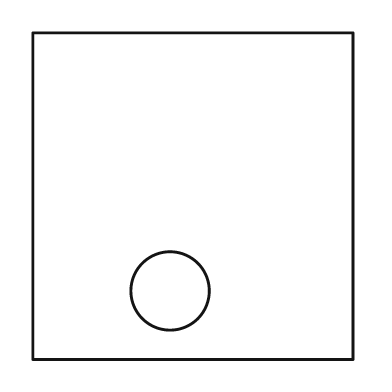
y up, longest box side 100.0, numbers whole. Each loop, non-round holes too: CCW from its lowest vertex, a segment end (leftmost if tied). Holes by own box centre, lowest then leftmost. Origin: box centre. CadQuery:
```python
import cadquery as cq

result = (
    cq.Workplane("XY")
    .moveTo(-49.0, -50.0)
    .lineTo(49.0, -50.0)
    .lineTo(49.0, 50.0)
    .lineTo(-49.0, 50.0)
    .close()
    .moveTo(-7.0, -29.0)
    .circle(12.0)
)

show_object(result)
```